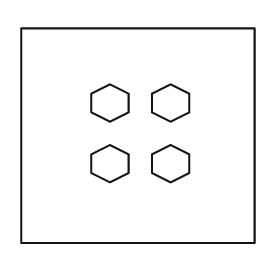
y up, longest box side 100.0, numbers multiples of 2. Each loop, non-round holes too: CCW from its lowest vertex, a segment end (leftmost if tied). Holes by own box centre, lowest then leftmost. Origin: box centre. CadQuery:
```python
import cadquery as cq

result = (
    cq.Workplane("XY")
    .moveTo(-50.0, -46.0)
    .lineTo(50.0, -46.0)
    .lineTo(50.0, 46.0)
    .lineTo(-50.0, 46.0)
    .close()
    .moveTo(-12.0, -20.0)
    .lineTo(-4.0, -16.0)
    .lineTo(-4.0, -8.0)
    .lineTo(-12.0, -4.0)
    .lineTo(-20.0, -8.0)
    .lineTo(-20.0, -16.0)
    .close()
    .moveTo(14.0, -20.0)
    .lineTo(22.0, -16.0)
    .lineTo(22.0, -8.0)
    .lineTo(14.0, -4.0)
    .lineTo(6.0, -8.0)
    .lineTo(6.0, -16.0)
    .close()
    .moveTo(-12.0, 6.0)
    .lineTo(-4.0, 10.0)
    .lineTo(-4.0, 18.0)
    .lineTo(-12.0, 22.0)
    .lineTo(-20.0, 18.0)
    .lineTo(-20.0, 10.0)
    .close()
    .moveTo(14.0, 6.0)
    .lineTo(22.0, 10.0)
    .lineTo(22.0, 18.0)
    .lineTo(14.0, 22.0)
    .lineTo(6.0, 18.0)
    .lineTo(6.0, 10.0)
    .close()
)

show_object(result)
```